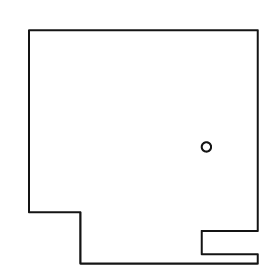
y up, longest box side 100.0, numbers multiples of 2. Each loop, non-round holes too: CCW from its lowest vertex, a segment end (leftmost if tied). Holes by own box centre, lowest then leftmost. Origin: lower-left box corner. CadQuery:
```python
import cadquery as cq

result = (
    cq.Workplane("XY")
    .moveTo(22.0, 0.0)
    .lineTo(98.0, 0.0)
    .lineTo(98.0, 4.0)
    .lineTo(74.0, 4.0)
    .lineTo(74.0, 14.0)
    .lineTo(98.0, 14.0)
    .lineTo(98.0, 100.0)
    .lineTo(0.0, 100.0)
    .lineTo(0.0, 22.0)
    .lineTo(22.0, 22.0)
    .close()
    .moveTo(76.0, 50.0)
    .circle(2.0)
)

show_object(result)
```